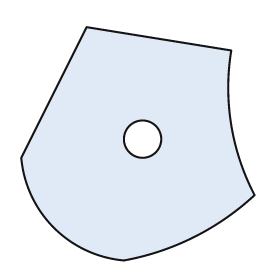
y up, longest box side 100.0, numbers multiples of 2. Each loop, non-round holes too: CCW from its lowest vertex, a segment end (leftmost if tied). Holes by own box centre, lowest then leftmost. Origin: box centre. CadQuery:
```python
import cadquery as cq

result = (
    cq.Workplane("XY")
    .moveTo(-6.0, -50.0)
    .threePointArc((24.0, -40.0), (50.0, -22.0))
    .threePointArc((40.0, 8.0), (40.0, 40.0))
    .lineTo(-22.0, 50.0)
    .lineTo(-50.0, -6.0)
    .threePointArc((-36.0, -36.0), (-6.0, -50.0))
    .close()
    .moveTo(2.0, 2.0)
    .circle(8.0)
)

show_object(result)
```